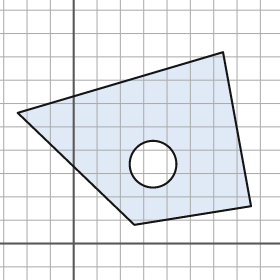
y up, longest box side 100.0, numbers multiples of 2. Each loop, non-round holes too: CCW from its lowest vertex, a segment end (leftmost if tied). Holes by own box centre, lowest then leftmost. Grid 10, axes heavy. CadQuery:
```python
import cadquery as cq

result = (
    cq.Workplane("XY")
    .moveTo(26.0, 8.0)
    .lineTo(76.0, 16.0)
    .lineTo(64.0, 82.0)
    .lineTo(-24.0, 56.0)
    .close()
    .moveTo(34.0, 34.0)
    .circle(10.0)
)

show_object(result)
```